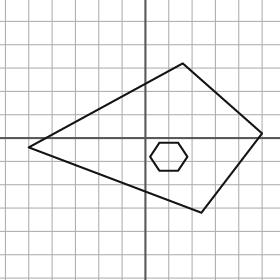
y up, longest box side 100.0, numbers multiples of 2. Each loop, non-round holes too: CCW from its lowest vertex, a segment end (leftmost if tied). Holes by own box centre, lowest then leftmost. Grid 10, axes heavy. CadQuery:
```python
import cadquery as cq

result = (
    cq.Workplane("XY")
    .moveTo(24.0, -32.0)
    .lineTo(50.0, 2.0)
    .lineTo(16.0, 32.0)
    .lineTo(-50.0, -4.0)
    .close()
    .moveTo(6.0, -14.0)
    .lineTo(14.0, -14.0)
    .lineTo(18.0, -8.0)
    .lineTo(14.0, -2.0)
    .lineTo(6.0, -2.0)
    .lineTo(2.0, -8.0)
    .close()
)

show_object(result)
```